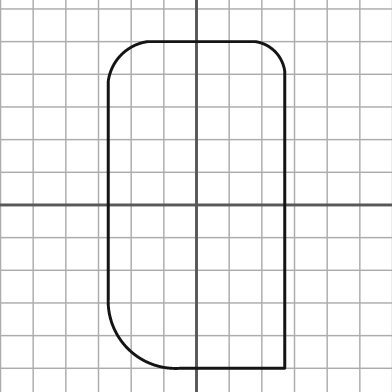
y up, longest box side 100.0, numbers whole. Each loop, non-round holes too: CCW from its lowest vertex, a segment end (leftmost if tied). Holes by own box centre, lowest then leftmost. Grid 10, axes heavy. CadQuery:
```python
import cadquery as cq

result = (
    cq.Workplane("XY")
    .moveTo(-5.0, -50.0)
    .lineTo(27.0, -50.0)
    .lineTo(27.0, 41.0)
    .threePointArc((24.0, 47.0), (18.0, 50.0))
    .lineTo(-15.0, 50.0)
    .threePointArc((-23.0, 46.0), (-27.0, 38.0))
    .lineTo(-27.0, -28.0)
    .threePointArc((-21.0, -44.0), (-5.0, -50.0))
    .close()
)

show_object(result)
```